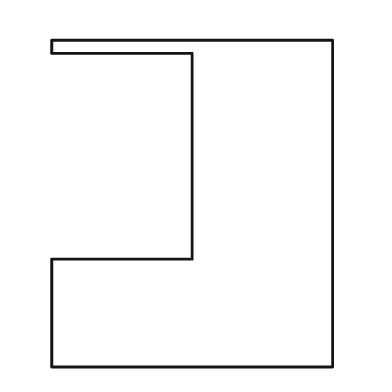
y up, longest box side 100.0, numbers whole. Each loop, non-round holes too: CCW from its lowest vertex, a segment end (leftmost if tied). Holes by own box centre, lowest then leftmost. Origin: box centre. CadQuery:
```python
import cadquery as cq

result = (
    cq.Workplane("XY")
    .moveTo(-43.0, -50.0)
    .lineTo(43.0, -50.0)
    .lineTo(43.0, 50.0)
    .lineTo(-43.0, 50.0)
    .lineTo(-43.0, 46.0)
    .lineTo(0.0, 46.0)
    .lineTo(0.0, -17.0)
    .lineTo(-43.0, -17.0)
    .close()
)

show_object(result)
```